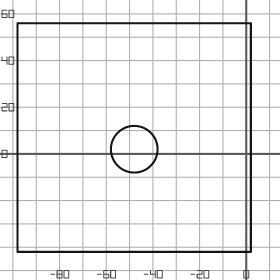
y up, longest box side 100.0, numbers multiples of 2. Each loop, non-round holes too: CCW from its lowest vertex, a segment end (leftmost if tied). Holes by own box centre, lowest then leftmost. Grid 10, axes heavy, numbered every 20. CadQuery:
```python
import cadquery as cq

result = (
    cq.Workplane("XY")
    .moveTo(-98.0, -42.0)
    .lineTo(2.0, -42.0)
    .lineTo(2.0, 56.0)
    .lineTo(-98.0, 56.0)
    .close()
    .moveTo(-48.0, 2.0)
    .circle(10.0)
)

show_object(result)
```